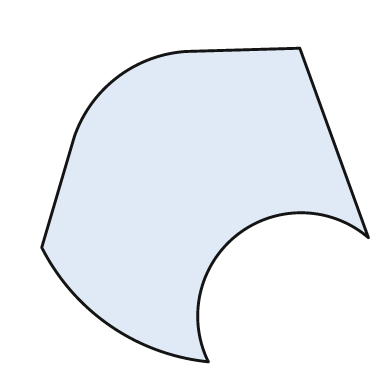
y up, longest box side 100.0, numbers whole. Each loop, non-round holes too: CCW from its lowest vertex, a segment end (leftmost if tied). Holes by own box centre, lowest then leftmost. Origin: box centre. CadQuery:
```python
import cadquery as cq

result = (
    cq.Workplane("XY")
    .moveTo(1.0, -48.0)
    .threePointArc((10.0, -9.0), (50.0, -10.0))
    .lineTo(29.0, 48.0)
    .lineTo(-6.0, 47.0)
    .threePointArc((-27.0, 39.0), (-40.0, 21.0))
    .lineTo(-50.0, -13.0)
    .threePointArc((-29.0, -37.0), (1.0, -48.0))
    .close()
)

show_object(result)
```